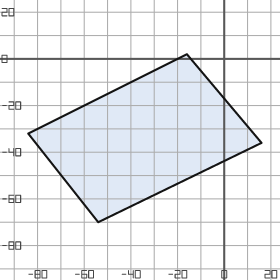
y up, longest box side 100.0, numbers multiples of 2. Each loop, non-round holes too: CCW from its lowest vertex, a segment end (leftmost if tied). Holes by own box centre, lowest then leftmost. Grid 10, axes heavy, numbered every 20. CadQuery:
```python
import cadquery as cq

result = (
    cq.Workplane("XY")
    .moveTo(-54.0, -70.0)
    .lineTo(16.0, -36.0)
    .lineTo(-16.0, 2.0)
    .lineTo(-84.0, -32.0)
    .close()
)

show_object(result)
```